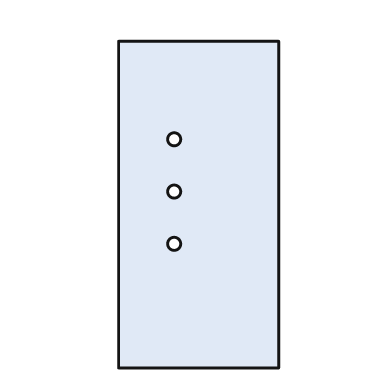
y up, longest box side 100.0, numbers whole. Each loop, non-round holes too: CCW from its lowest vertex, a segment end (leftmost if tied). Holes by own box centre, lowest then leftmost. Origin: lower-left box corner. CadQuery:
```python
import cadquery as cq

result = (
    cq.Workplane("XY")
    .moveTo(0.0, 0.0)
    .lineTo(49.0, 0.0)
    .lineTo(49.0, 100.0)
    .lineTo(0.0, 100.0)
    .close()
    .moveTo(17.0, 38.0)
    .circle(2.0)
    .moveTo(17.0, 54.0)
    .circle(2.0)
    .moveTo(17.0, 70.0)
    .circle(2.0)
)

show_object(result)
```